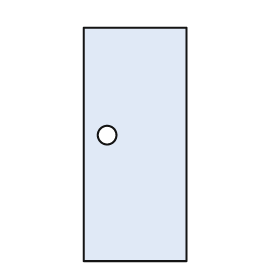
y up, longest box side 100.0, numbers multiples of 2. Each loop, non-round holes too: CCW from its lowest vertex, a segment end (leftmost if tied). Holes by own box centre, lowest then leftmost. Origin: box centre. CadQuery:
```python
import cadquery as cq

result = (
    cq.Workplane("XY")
    .moveTo(-22.0, -50.0)
    .lineTo(22.0, -50.0)
    .lineTo(22.0, 50.0)
    .lineTo(-22.0, 50.0)
    .close()
    .moveTo(-12.0, 4.0)
    .circle(4.0)
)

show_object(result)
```